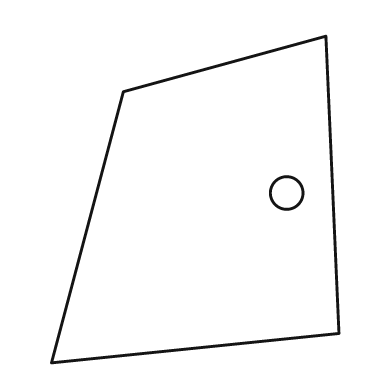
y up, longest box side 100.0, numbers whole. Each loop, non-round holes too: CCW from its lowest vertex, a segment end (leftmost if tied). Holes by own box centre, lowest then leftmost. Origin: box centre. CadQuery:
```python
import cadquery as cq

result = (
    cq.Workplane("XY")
    .moveTo(-44.0, -50.0)
    .lineTo(44.0, -41.0)
    .lineTo(40.0, 50.0)
    .lineTo(-22.0, 33.0)
    .close()
    .moveTo(28.0, 2.0)
    .circle(5.0)
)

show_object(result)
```